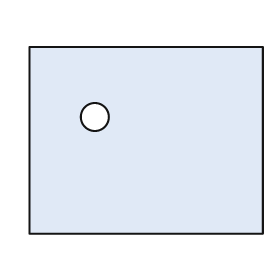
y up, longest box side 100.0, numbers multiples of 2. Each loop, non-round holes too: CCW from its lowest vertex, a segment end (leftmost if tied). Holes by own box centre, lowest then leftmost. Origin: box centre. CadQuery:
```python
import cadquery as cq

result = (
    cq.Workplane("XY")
    .moveTo(-50.0, -40.0)
    .lineTo(50.0, -40.0)
    .lineTo(50.0, 40.0)
    .lineTo(-50.0, 40.0)
    .close()
    .moveTo(-22.0, 10.0)
    .circle(6.0)
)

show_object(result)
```